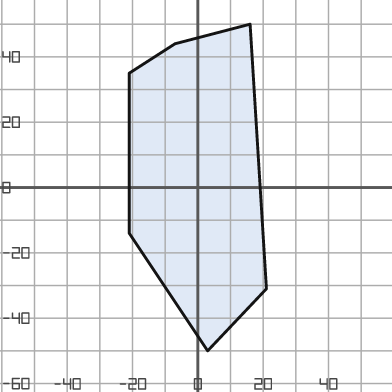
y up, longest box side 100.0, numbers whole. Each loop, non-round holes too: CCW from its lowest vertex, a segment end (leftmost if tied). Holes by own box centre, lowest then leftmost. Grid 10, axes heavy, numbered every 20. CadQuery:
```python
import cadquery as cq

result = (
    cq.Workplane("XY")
    .moveTo(3.0, -50.0)
    .lineTo(21.0, -31.0)
    .lineTo(16.0, 50.0)
    .lineTo(-7.0, 44.0)
    .lineTo(-21.0, 35.0)
    .lineTo(-21.0, -14.0)
    .close()
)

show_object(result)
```